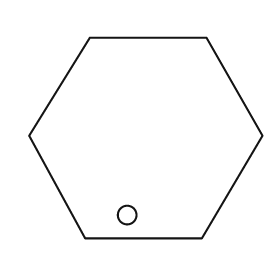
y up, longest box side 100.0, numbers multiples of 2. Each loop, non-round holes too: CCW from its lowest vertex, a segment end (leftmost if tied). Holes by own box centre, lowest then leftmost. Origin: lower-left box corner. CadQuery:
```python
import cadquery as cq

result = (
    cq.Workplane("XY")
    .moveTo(24.0, 0.0)
    .lineTo(74.0, 0.0)
    .lineTo(100.0, 44.0)
    .lineTo(76.0, 86.0)
    .lineTo(26.0, 86.0)
    .lineTo(0.0, 44.0)
    .close()
    .moveTo(42.0, 10.0)
    .circle(4.0)
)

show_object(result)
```